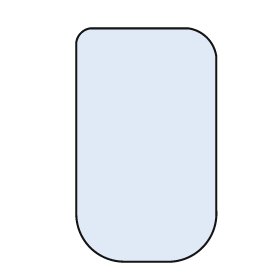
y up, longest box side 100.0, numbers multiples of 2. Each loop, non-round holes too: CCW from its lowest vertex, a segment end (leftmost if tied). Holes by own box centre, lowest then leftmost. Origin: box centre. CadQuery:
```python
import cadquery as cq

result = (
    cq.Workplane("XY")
    .moveTo(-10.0, -50.0)
    .lineTo(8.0, -50.0)
    .threePointArc((24.0, -44.0), (30.0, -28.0))
    .lineTo(30.0, 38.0)
    .threePointArc((26.0, 46.0), (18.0, 50.0))
    .lineTo(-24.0, 50.0)
    .threePointArc((-28.0, 48.0), (-30.0, 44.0))
    .lineTo(-30.0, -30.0)
    .threePointArc((-24.0, -44.0), (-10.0, -50.0))
    .close()
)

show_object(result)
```